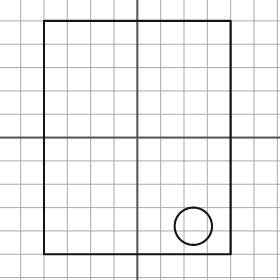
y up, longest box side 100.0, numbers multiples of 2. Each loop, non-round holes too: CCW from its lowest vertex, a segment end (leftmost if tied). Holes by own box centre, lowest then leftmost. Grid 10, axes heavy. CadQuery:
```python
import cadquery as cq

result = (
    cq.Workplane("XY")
    .moveTo(-40.0, -50.0)
    .lineTo(40.0, -50.0)
    .lineTo(40.0, 50.0)
    .lineTo(-40.0, 50.0)
    .close()
    .moveTo(24.0, -38.0)
    .circle(8.0)
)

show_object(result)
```